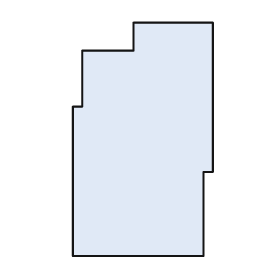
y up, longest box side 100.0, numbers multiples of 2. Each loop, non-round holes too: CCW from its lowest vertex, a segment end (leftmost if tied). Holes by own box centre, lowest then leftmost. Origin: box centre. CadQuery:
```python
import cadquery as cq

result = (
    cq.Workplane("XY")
    .moveTo(-30.0, -50.0)
    .lineTo(26.0, -50.0)
    .lineTo(26.0, -14.0)
    .lineTo(30.0, -14.0)
    .lineTo(30.0, 50.0)
    .lineTo(-4.0, 50.0)
    .lineTo(-4.0, 38.0)
    .lineTo(-26.0, 38.0)
    .lineTo(-26.0, 14.0)
    .lineTo(-30.0, 14.0)
    .close()
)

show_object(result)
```